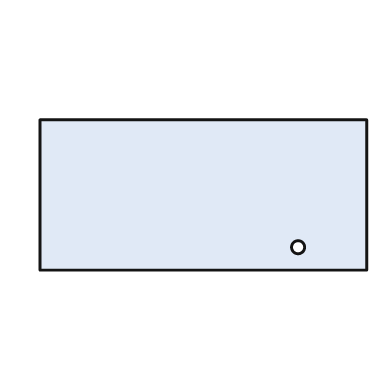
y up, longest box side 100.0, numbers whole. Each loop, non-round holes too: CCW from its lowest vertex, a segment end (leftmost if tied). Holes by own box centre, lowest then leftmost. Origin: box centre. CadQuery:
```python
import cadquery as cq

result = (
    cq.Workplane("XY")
    .moveTo(-50.0, -23.0)
    .lineTo(50.0, -23.0)
    .lineTo(50.0, 23.0)
    .lineTo(-50.0, 23.0)
    .close()
    .moveTo(29.0, -16.0)
    .circle(2.0)
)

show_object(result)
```